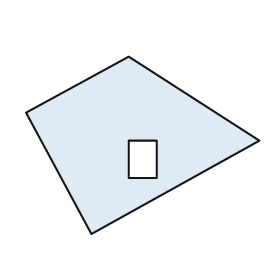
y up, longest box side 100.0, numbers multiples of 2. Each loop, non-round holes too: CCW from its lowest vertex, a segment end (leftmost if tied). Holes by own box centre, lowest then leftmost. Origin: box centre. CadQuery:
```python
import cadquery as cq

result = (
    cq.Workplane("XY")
    .moveTo(-22.0, -38.0)
    .lineTo(50.0, 2.0)
    .lineTo(-6.0, 38.0)
    .lineTo(-50.0, 14.0)
    .close()
    .moveTo(-6.0, -14.0)
    .lineTo(6.0, -14.0)
    .lineTo(6.0, 2.0)
    .lineTo(-6.0, 2.0)
    .close()
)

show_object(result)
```